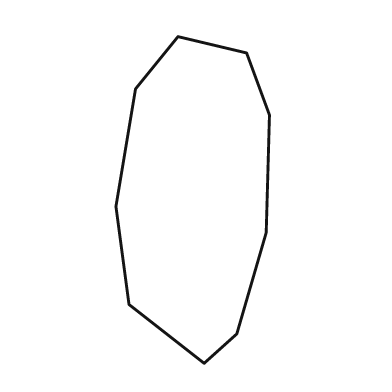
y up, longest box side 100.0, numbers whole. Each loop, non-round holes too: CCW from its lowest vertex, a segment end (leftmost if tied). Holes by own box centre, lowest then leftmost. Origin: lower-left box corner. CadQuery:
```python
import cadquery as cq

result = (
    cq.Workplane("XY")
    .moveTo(27.0, 0.0)
    .lineTo(37.0, 9.0)
    .lineTo(46.0, 40.0)
    .lineTo(47.0, 76.0)
    .lineTo(40.0, 95.0)
    .lineTo(19.0, 100.0)
    .lineTo(6.0, 84.0)
    .lineTo(0.0, 48.0)
    .lineTo(4.0, 18.0)
    .close()
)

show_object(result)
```